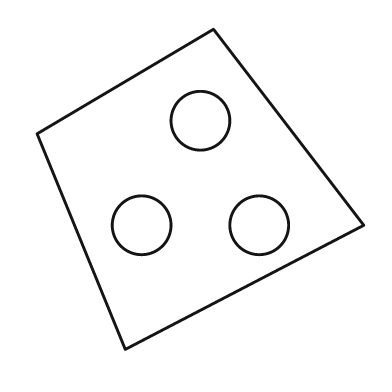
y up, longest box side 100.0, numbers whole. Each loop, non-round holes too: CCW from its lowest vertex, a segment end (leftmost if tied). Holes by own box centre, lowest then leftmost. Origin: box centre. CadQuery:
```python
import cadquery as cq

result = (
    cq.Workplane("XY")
    .moveTo(-23.0, -49.0)
    .lineTo(50.0, -11.0)
    .lineTo(4.0, 49.0)
    .lineTo(-50.0, 17.0)
    .close()
    .moveTo(-18.0, -11.0)
    .circle(9.0)
    .moveTo(18.0, -11.0)
    .circle(9.0)
    .moveTo(0.0, 21.0)
    .circle(9.0)
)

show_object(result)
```